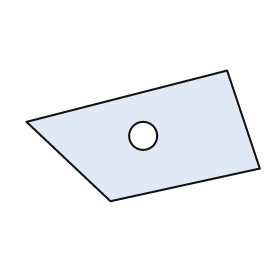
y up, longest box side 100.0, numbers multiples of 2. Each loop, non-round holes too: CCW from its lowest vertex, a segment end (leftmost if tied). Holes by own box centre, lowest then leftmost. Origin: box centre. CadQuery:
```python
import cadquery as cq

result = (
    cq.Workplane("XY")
    .moveTo(-14.0, -28.0)
    .lineTo(50.0, -14.0)
    .lineTo(36.0, 28.0)
    .lineTo(-50.0, 6.0)
    .close()
    .moveTo(0.0, 0.0)
    .circle(6.0)
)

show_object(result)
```